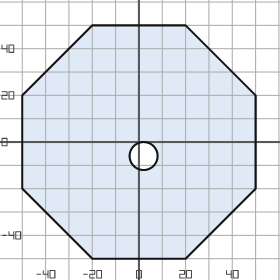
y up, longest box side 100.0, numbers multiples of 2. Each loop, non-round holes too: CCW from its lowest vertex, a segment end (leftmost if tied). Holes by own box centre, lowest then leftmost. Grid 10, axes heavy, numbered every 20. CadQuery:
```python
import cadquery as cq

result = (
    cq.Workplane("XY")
    .moveTo(-20.0, -50.0)
    .lineTo(20.0, -50.0)
    .lineTo(50.0, -20.0)
    .lineTo(50.0, 20.0)
    .lineTo(20.0, 50.0)
    .lineTo(-20.0, 50.0)
    .lineTo(-50.0, 20.0)
    .lineTo(-50.0, -20.0)
    .close()
    .moveTo(2.0, -6.0)
    .circle(6.0)
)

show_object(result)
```